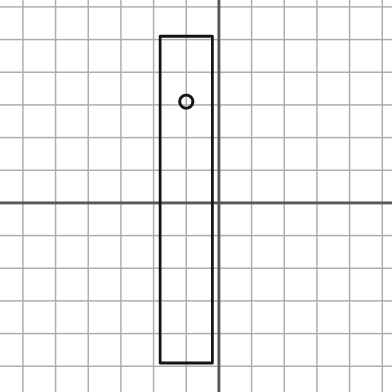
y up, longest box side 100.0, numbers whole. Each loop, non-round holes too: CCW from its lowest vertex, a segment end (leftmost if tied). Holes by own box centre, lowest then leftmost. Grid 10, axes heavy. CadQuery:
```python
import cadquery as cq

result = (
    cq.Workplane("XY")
    .moveTo(-18.0, -49.0)
    .lineTo(-2.0, -49.0)
    .lineTo(-2.0, 51.0)
    .lineTo(-18.0, 51.0)
    .close()
    .moveTo(-10.0, 31.0)
    .circle(2.0)
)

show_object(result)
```